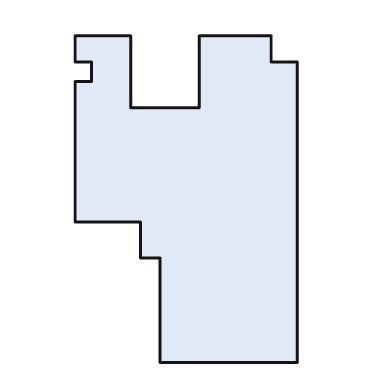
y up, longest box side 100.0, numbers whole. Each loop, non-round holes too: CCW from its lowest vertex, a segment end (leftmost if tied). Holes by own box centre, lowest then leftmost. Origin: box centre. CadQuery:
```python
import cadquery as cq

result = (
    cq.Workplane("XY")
    .moveTo(-8.0, -50.0)
    .lineTo(34.0, -50.0)
    .lineTo(34.0, 42.0)
    .lineTo(26.0, 42.0)
    .lineTo(26.0, 50.0)
    .lineTo(4.0, 50.0)
    .lineTo(4.0, 28.0)
    .lineTo(-17.0, 28.0)
    .lineTo(-17.0, 50.0)
    .lineTo(-34.0, 50.0)
    .lineTo(-34.0, 42.0)
    .lineTo(-29.0, 42.0)
    .lineTo(-29.0, 36.0)
    .lineTo(-34.0, 36.0)
    .lineTo(-34.0, -7.0)
    .lineTo(-14.0, -7.0)
    .lineTo(-14.0, -18.0)
    .lineTo(-8.0, -18.0)
    .close()
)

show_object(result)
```